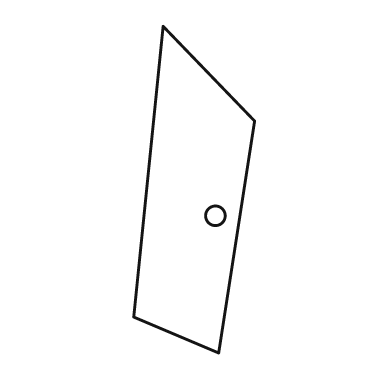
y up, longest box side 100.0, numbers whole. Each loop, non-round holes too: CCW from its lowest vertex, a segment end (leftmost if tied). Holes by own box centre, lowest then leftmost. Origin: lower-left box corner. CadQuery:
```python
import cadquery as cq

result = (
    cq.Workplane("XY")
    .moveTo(26.0, 0.0)
    .lineTo(37.0, 71.0)
    .lineTo(9.0, 100.0)
    .lineTo(0.0, 11.0)
    .close()
    .moveTo(25.0, 42.0)
    .circle(3.0)
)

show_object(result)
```